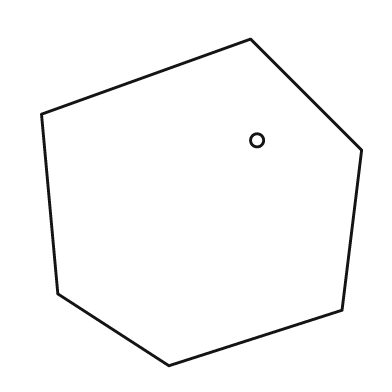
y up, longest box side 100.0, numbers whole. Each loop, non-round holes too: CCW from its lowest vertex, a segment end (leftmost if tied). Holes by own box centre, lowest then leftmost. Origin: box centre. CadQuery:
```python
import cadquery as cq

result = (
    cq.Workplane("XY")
    .moveTo(-10.0, -50.0)
    .lineTo(43.0, -33.0)
    .lineTo(49.0, 16.0)
    .lineTo(15.0, 50.0)
    .lineTo(-49.0, 27.0)
    .lineTo(-44.0, -28.0)
    .close()
    .moveTo(17.0, 19.0)
    .circle(2.0)
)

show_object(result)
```